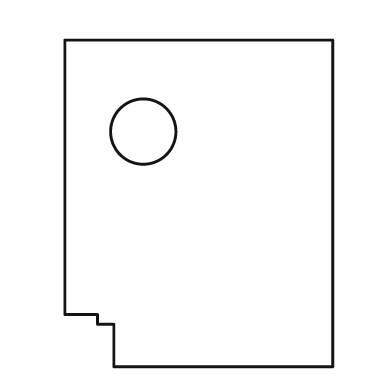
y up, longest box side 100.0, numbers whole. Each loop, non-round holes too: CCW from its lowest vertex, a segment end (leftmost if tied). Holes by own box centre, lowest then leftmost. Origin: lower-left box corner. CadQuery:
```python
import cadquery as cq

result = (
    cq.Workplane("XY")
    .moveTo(15.0, 0.0)
    .lineTo(82.0, 0.0)
    .lineTo(82.0, 100.0)
    .lineTo(0.0, 100.0)
    .lineTo(0.0, 16.0)
    .lineTo(10.0, 16.0)
    .lineTo(10.0, 13.0)
    .lineTo(15.0, 13.0)
    .close()
    .moveTo(24.0, 72.0)
    .circle(10.0)
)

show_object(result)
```